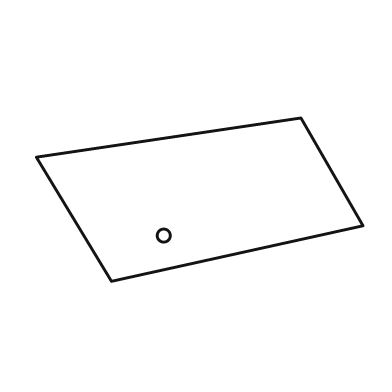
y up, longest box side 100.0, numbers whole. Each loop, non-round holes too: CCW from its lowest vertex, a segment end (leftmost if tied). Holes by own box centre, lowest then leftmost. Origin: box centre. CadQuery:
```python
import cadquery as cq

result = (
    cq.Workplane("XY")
    .moveTo(-27.0, -25.0)
    .lineTo(50.0, -8.0)
    .lineTo(31.0, 25.0)
    .lineTo(-50.0, 13.0)
    .close()
    .moveTo(-11.0, -11.0)
    .circle(2.0)
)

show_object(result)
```